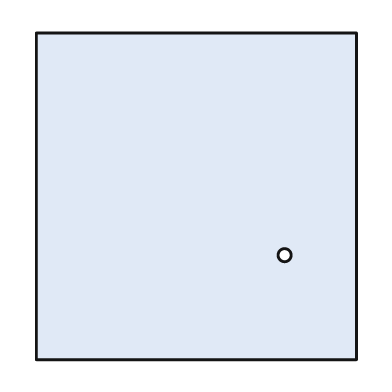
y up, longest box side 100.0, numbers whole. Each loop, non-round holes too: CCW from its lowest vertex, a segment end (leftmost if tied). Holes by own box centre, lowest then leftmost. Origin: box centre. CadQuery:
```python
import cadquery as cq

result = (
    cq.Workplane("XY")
    .moveTo(-49.0, -50.0)
    .lineTo(49.0, -50.0)
    .lineTo(49.0, 50.0)
    .lineTo(-49.0, 50.0)
    .close()
    .moveTo(27.0, -18.0)
    .circle(2.0)
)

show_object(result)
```